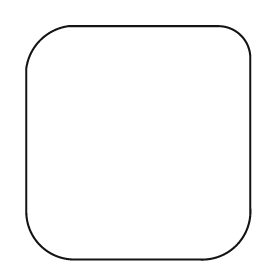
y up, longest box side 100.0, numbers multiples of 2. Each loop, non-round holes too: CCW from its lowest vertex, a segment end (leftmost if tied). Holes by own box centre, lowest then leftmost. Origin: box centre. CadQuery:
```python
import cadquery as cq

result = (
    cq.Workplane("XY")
    .moveTo(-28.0, -50.0)
    .lineTo(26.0, -50.0)
    .threePointArc((42.0, -44.0), (48.0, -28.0))
    .lineTo(48.0, 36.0)
    .threePointArc((44.0, 46.0), (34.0, 50.0))
    .lineTo(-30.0, 50.0)
    .threePointArc((-42.0, 44.0), (-48.0, 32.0))
    .lineTo(-48.0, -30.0)
    .threePointArc((-42.0, -44.0), (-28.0, -50.0))
    .close()
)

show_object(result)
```